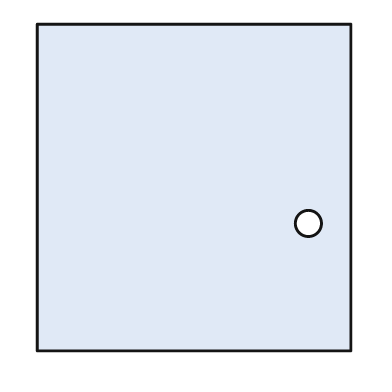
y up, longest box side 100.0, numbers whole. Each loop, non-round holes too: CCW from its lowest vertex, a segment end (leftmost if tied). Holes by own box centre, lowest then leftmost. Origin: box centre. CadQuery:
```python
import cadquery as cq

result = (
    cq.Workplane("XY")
    .moveTo(-48.0, -50.0)
    .lineTo(48.0, -50.0)
    .lineTo(48.0, 50.0)
    .lineTo(-48.0, 50.0)
    .close()
    .moveTo(35.0, -11.0)
    .circle(4.0)
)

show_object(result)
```